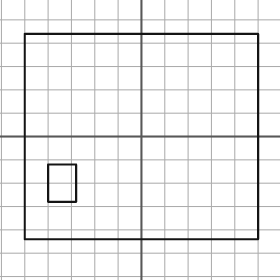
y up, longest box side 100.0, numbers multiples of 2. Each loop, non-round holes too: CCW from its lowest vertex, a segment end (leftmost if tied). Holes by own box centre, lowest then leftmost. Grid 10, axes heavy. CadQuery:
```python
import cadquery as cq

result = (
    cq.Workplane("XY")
    .moveTo(-50.0, -44.0)
    .lineTo(50.0, -44.0)
    .lineTo(50.0, 44.0)
    .lineTo(-50.0, 44.0)
    .close()
    .moveTo(-40.0, -28.0)
    .lineTo(-28.0, -28.0)
    .lineTo(-28.0, -12.0)
    .lineTo(-40.0, -12.0)
    .close()
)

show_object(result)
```